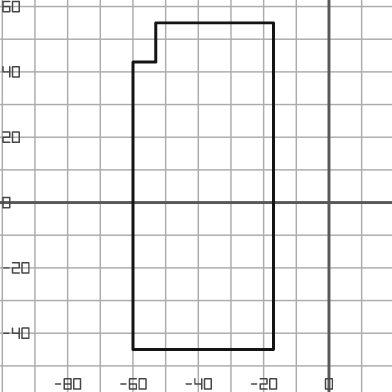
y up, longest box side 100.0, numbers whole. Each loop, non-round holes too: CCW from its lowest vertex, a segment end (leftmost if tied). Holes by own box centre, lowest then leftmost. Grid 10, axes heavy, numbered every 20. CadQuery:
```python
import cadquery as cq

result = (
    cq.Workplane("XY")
    .moveTo(-60.0, -45.0)
    .lineTo(-17.0, -45.0)
    .lineTo(-17.0, 55.0)
    .lineTo(-53.0, 55.0)
    .lineTo(-53.0, 43.0)
    .lineTo(-60.0, 43.0)
    .close()
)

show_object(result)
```